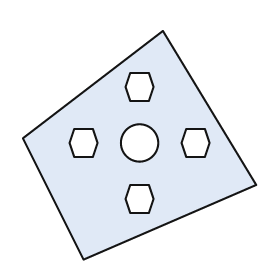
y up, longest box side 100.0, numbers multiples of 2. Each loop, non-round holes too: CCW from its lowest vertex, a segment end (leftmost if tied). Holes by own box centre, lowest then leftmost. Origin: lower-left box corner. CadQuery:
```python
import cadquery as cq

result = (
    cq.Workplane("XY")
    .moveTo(26.0, 0.0)
    .lineTo(100.0, 32.0)
    .lineTo(60.0, 98.0)
    .lineTo(0.0, 52.0)
    .close()
    .moveTo(46.0, 20.0)
    .lineTo(54.0, 20.0)
    .lineTo(56.0, 26.0)
    .lineTo(54.0, 32.0)
    .lineTo(46.0, 32.0)
    .lineTo(44.0, 26.0)
    .close()
    .moveTo(22.0, 44.0)
    .lineTo(30.0, 44.0)
    .lineTo(32.0, 50.0)
    .lineTo(30.0, 56.0)
    .lineTo(22.0, 56.0)
    .lineTo(20.0, 50.0)
    .close()
    .moveTo(50.0, 50.0)
    .circle(8.0)
    .moveTo(70.0, 44.0)
    .lineTo(78.0, 44.0)
    .lineTo(80.0, 50.0)
    .lineTo(78.0, 56.0)
    .lineTo(70.0, 56.0)
    .lineTo(68.0, 50.0)
    .close()
    .moveTo(46.0, 68.0)
    .lineTo(54.0, 68.0)
    .lineTo(56.0, 74.0)
    .lineTo(54.0, 80.0)
    .lineTo(46.0, 80.0)
    .lineTo(44.0, 74.0)
    .close()
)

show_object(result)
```